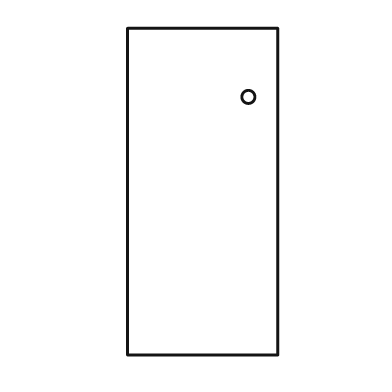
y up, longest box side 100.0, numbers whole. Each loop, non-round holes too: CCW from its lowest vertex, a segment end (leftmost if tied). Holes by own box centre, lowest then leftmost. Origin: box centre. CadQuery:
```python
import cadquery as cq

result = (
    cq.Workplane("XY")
    .moveTo(-23.0, -50.0)
    .lineTo(23.0, -50.0)
    .lineTo(23.0, 50.0)
    .lineTo(-23.0, 50.0)
    .close()
    .moveTo(14.0, 29.0)
    .circle(2.0)
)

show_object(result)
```